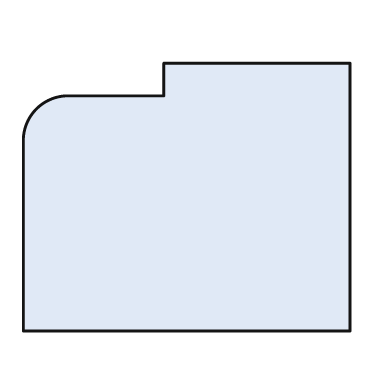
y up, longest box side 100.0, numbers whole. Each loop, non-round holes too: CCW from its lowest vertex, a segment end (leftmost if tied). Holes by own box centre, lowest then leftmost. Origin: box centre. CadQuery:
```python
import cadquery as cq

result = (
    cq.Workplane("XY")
    .moveTo(-50.0, -41.0)
    .lineTo(50.0, -41.0)
    .lineTo(50.0, 41.0)
    .lineTo(-7.0, 41.0)
    .lineTo(-7.0, 31.0)
    .lineTo(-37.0, 31.0)
    .threePointArc((-46.0, 27.0), (-50.0, 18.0))
    .close()
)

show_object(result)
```